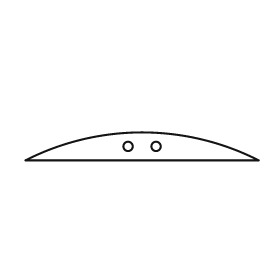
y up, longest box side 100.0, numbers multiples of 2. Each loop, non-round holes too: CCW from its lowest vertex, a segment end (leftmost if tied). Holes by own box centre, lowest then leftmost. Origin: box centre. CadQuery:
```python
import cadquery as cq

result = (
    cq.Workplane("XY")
    .moveTo(-50.0, -6.0)
    .lineTo(50.0, -6.0)
    .threePointArc((0.0, 6.0), (-50.0, -6.0))
    .close()
    .moveTo(-6.0, 0.0)
    .circle(2.0)
    .moveTo(6.0, 0.0)
    .circle(2.0)
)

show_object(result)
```